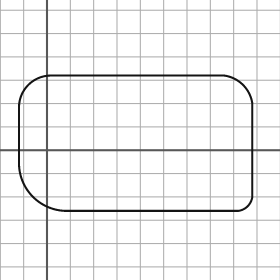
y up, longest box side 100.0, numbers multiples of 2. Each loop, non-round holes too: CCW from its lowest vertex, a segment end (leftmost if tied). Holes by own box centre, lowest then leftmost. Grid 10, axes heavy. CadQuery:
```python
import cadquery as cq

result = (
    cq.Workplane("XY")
    .moveTo(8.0, -26.0)
    .lineTo(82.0, -26.0)
    .threePointArc((86.0, -24.0), (88.0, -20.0))
    .lineTo(88.0, 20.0)
    .threePointArc((84.0, 28.0), (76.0, 32.0))
    .lineTo(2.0, 32.0)
    .threePointArc((-8.0, 28.0), (-12.0, 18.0))
    .lineTo(-12.0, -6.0)
    .threePointArc((-6.0, -20.0), (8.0, -26.0))
    .close()
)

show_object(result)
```